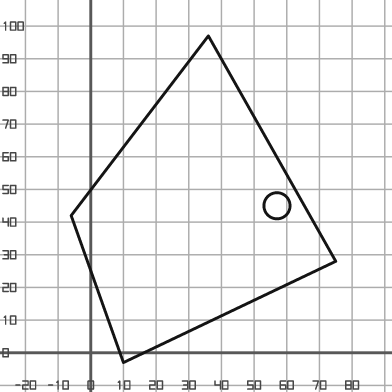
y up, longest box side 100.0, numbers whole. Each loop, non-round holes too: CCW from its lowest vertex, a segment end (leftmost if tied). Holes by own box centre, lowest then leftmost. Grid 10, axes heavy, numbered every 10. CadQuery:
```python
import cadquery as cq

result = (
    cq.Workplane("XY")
    .moveTo(10.0, -3.0)
    .lineTo(75.0, 28.0)
    .lineTo(36.0, 97.0)
    .lineTo(-6.0, 42.0)
    .close()
    .moveTo(57.0, 45.0)
    .circle(4.0)
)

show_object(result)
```